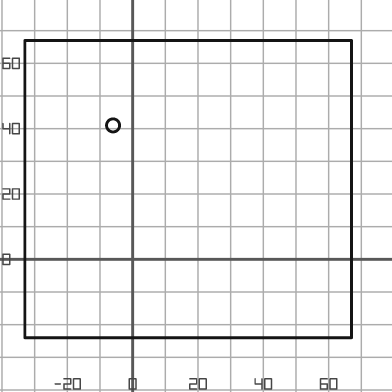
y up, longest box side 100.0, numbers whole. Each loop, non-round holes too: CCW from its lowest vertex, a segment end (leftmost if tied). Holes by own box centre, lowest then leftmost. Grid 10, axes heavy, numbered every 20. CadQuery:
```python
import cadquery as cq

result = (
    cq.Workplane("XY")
    .moveTo(-33.0, -24.0)
    .lineTo(67.0, -24.0)
    .lineTo(67.0, 67.0)
    .lineTo(-33.0, 67.0)
    .close()
    .moveTo(-6.0, 41.0)
    .circle(2.0)
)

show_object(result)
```